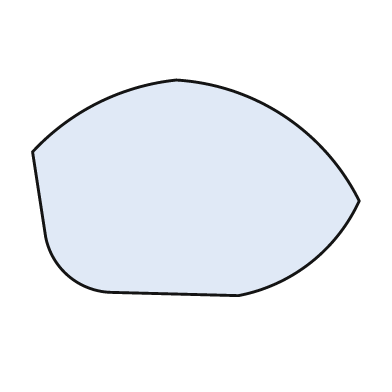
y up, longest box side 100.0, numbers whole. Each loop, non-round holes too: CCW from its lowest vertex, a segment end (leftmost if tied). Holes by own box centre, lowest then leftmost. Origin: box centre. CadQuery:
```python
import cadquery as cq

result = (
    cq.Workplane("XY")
    .moveTo(13.0, -33.0)
    .threePointArc((35.0, -23.0), (50.0, -4.0))
    .threePointArc((27.0, 22.0), (-6.0, 33.0))
    .threePointArc((-30.0, 26.0), (-50.0, 11.0))
    .lineTo(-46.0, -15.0)
    .threePointArc((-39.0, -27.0), (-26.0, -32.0))
    .close()
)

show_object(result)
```